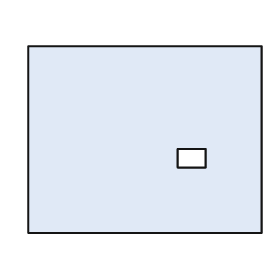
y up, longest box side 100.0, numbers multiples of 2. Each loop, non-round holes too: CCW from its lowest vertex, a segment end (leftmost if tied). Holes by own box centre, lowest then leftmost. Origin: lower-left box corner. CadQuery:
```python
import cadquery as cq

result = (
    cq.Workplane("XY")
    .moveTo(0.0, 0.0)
    .lineTo(100.0, 0.0)
    .lineTo(100.0, 80.0)
    .lineTo(0.0, 80.0)
    .close()
    .moveTo(64.0, 28.0)
    .lineTo(76.0, 28.0)
    .lineTo(76.0, 36.0)
    .lineTo(64.0, 36.0)
    .close()
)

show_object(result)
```